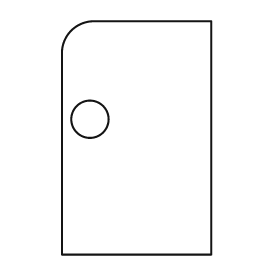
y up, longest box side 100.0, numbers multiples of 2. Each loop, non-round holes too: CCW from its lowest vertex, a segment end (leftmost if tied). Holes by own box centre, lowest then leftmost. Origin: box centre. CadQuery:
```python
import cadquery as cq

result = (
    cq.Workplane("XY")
    .moveTo(-32.0, -50.0)
    .lineTo(32.0, -50.0)
    .lineTo(32.0, 50.0)
    .lineTo(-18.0, 50.0)
    .threePointArc((-28.0, 46.0), (-32.0, 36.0))
    .close()
    .moveTo(-20.0, 8.0)
    .circle(8.0)
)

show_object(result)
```